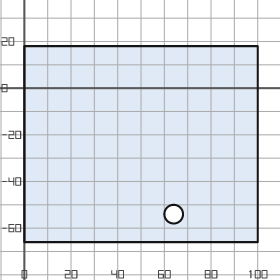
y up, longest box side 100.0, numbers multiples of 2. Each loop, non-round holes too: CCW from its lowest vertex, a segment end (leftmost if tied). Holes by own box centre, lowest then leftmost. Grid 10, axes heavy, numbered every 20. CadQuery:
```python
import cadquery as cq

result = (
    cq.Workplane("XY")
    .moveTo(0.0, -66.0)
    .lineTo(100.0, -66.0)
    .lineTo(100.0, 18.0)
    .lineTo(0.0, 18.0)
    .close()
    .moveTo(64.0, -54.0)
    .circle(4.0)
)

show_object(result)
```